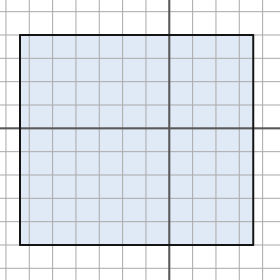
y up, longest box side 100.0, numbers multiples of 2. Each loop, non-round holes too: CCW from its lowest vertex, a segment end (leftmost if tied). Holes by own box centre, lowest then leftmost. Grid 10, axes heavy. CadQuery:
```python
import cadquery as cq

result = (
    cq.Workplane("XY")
    .moveTo(-64.0, -50.0)
    .lineTo(36.0, -50.0)
    .lineTo(36.0, 40.0)
    .lineTo(-64.0, 40.0)
    .close()
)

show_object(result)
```